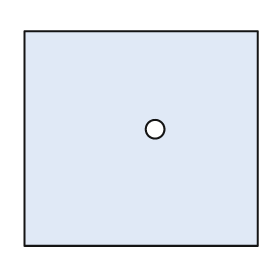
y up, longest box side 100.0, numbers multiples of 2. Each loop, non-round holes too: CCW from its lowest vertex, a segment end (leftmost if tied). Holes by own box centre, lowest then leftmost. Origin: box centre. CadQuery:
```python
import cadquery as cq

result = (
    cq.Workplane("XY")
    .moveTo(-50.0, -46.0)
    .lineTo(50.0, -46.0)
    .lineTo(50.0, 46.0)
    .lineTo(-50.0, 46.0)
    .close()
    .moveTo(6.0, 4.0)
    .circle(4.0)
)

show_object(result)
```